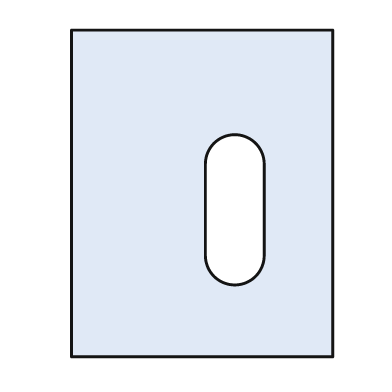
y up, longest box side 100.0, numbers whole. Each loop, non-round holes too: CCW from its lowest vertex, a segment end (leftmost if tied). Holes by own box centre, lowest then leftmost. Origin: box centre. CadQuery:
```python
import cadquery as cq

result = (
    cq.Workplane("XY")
    .moveTo(-40.0, -50.0)
    .lineTo(40.0, -50.0)
    .lineTo(40.0, 50.0)
    .lineTo(-40.0, 50.0)
    .close()
    .moveTo(1.0, -19.0)
    .threePointArc((10.0, -28.0), (19.0, -19.0))
    .lineTo(19.0, 9.0)
    .threePointArc((10.0, 18.0), (1.0, 9.0))
    .close()
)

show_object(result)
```